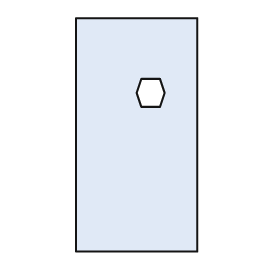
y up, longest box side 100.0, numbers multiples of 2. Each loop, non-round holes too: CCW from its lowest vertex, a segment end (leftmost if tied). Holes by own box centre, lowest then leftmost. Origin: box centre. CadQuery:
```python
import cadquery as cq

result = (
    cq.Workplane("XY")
    .moveTo(-26.0, -50.0)
    .lineTo(26.0, -50.0)
    .lineTo(26.0, 50.0)
    .lineTo(-26.0, 50.0)
    .close()
    .moveTo(2.0, 12.0)
    .lineTo(10.0, 12.0)
    .lineTo(12.0, 18.0)
    .lineTo(10.0, 24.0)
    .lineTo(2.0, 24.0)
    .lineTo(0.0, 18.0)
    .close()
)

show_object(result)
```